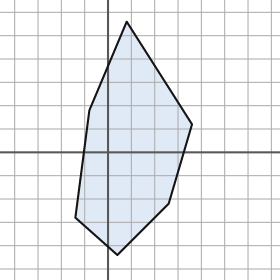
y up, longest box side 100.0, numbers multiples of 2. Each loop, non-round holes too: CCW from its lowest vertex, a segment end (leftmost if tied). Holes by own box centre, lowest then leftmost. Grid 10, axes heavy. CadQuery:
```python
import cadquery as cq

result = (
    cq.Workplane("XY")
    .moveTo(4.0, -44.0)
    .lineTo(26.0, -22.0)
    .lineTo(36.0, 12.0)
    .lineTo(8.0, 56.0)
    .lineTo(-8.0, 18.0)
    .lineTo(-14.0, -28.0)
    .close()
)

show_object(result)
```